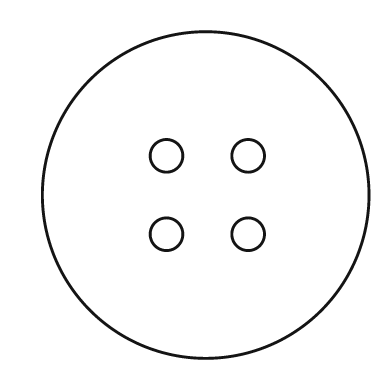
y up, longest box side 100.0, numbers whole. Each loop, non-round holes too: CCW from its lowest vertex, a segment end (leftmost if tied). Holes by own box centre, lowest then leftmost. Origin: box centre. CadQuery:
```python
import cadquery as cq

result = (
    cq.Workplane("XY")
    .moveTo(0.0, 0.0)
    .circle(50.0)
    .moveTo(-12.0, -12.0)
    .circle(5.0)
    .moveTo(13.0, -12.0)
    .circle(5.0)
    .moveTo(-12.0, 12.0)
    .circle(5.0)
    .moveTo(13.0, 12.0)
    .circle(5.0)
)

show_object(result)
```